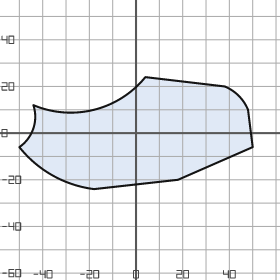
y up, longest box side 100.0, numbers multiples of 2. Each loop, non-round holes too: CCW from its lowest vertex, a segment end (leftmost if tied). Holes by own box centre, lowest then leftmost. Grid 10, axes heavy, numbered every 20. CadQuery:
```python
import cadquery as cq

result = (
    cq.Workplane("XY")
    .moveTo(-18.0, -24.0)
    .lineTo(18.0, -20.0)
    .lineTo(50.0, -6.0)
    .lineTo(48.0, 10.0)
    .threePointArc((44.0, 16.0), (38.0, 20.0))
    .lineTo(4.0, 24.0)
    .threePointArc((-18.0, 10.0), (-44.0, 12.0))
    .threePointArc((-44.0, 2.0), (-50.0, -6.0))
    .threePointArc((-36.0, -18.0), (-18.0, -24.0))
    .close()
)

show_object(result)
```